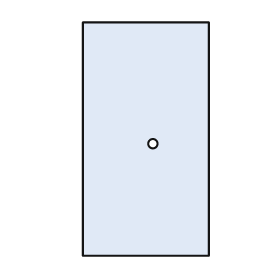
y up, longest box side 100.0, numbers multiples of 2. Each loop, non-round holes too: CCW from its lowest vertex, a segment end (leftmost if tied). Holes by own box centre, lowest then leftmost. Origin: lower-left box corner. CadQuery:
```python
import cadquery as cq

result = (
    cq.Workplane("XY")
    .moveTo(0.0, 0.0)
    .lineTo(54.0, 0.0)
    .lineTo(54.0, 100.0)
    .lineTo(0.0, 100.0)
    .close()
    .moveTo(30.0, 48.0)
    .circle(2.0)
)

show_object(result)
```